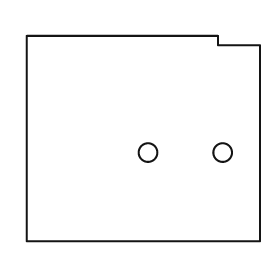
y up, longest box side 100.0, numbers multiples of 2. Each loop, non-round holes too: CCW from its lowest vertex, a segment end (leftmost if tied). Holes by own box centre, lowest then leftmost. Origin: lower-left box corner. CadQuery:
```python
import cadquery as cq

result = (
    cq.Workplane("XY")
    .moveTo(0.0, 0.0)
    .lineTo(100.0, 0.0)
    .lineTo(100.0, 84.0)
    .lineTo(82.0, 84.0)
    .lineTo(82.0, 88.0)
    .lineTo(0.0, 88.0)
    .close()
    .moveTo(52.0, 38.0)
    .circle(4.0)
    .moveTo(84.0, 38.0)
    .circle(4.0)
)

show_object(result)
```